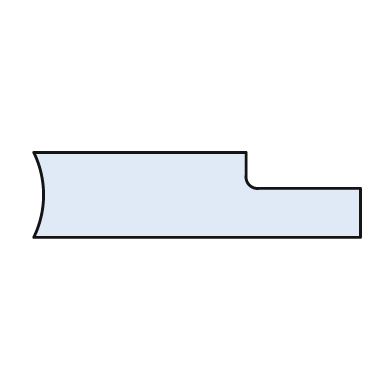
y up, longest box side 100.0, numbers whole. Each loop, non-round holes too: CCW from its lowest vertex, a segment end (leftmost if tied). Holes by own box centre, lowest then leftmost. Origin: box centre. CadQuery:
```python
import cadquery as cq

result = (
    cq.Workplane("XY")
    .moveTo(-50.0, -13.0)
    .lineTo(50.0, -13.0)
    .lineTo(50.0, 2.0)
    .lineTo(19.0, 2.0)
    .threePointArc((16.0, 3.0), (15.0, 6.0))
    .lineTo(15.0, 13.0)
    .lineTo(-50.0, 13.0)
    .threePointArc((-47.0, 0.0), (-50.0, -13.0))
    .close()
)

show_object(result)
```